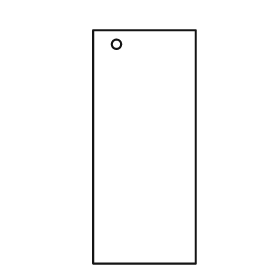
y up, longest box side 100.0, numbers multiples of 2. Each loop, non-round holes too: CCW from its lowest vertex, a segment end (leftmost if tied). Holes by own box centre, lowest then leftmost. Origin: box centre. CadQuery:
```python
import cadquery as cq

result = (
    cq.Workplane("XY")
    .moveTo(-22.0, -50.0)
    .lineTo(22.0, -50.0)
    .lineTo(22.0, 50.0)
    .lineTo(-22.0, 50.0)
    .close()
    .moveTo(-12.0, 44.0)
    .circle(2.0)
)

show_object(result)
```